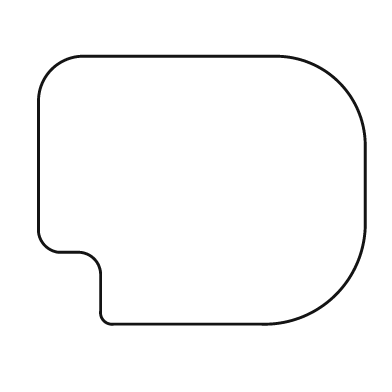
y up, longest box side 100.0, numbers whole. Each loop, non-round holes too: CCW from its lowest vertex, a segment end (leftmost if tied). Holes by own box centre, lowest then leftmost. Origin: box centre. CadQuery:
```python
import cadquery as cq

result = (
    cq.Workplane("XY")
    .moveTo(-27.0, -41.0)
    .lineTo(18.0, -41.0)
    .threePointArc((41.0, -32.0), (50.0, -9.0))
    .lineTo(50.0, 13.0)
    .threePointArc((42.0, 33.0), (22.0, 41.0))
    .lineTo(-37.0, 41.0)
    .threePointArc((-46.0, 37.0), (-50.0, 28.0))
    .lineTo(-50.0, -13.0)
    .threePointArc((-48.0, -17.0), (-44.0, -19.0))
    .lineTo(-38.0, -19.0)
    .threePointArc((-33.0, -21.0), (-31.0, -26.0))
    .lineTo(-31.0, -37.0)
    .threePointArc((-30.0, -40.0), (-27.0, -41.0))
    .close()
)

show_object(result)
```